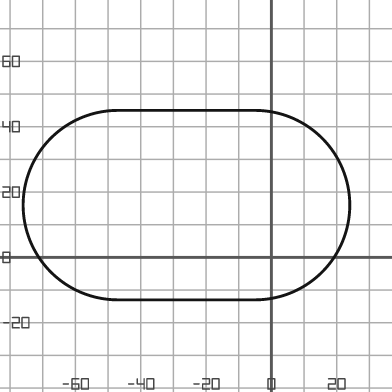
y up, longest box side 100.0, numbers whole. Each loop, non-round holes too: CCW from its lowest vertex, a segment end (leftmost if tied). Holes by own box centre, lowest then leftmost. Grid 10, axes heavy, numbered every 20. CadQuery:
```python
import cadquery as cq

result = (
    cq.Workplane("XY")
    .moveTo(-47.0, -13.0)
    .lineTo(-5.0, -13.0)
    .threePointArc((24.0, 16.0), (-5.0, 45.0))
    .lineTo(-47.0, 45.0)
    .threePointArc((-76.0, 16.0), (-47.0, -13.0))
    .close()
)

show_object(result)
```